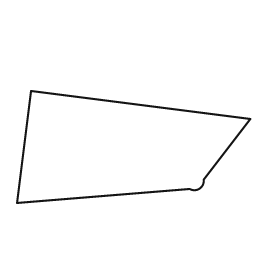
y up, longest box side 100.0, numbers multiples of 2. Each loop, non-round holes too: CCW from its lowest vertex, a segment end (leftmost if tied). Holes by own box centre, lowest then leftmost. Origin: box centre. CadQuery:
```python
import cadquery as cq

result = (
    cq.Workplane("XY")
    .moveTo(-50.0, -24.0)
    .lineTo(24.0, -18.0)
    .threePointArc((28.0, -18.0), (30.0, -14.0))
    .lineTo(50.0, 12.0)
    .lineTo(-44.0, 24.0)
    .close()
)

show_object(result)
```